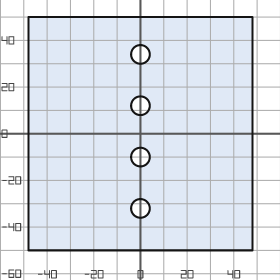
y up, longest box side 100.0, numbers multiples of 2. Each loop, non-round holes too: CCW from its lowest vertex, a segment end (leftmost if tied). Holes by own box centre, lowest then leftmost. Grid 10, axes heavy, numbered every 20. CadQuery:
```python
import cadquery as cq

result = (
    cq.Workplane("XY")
    .moveTo(-48.0, -50.0)
    .lineTo(48.0, -50.0)
    .lineTo(48.0, 50.0)
    .lineTo(-48.0, 50.0)
    .close()
    .moveTo(0.0, -32.0)
    .circle(4.0)
    .moveTo(0.0, -10.0)
    .circle(4.0)
    .moveTo(0.0, 12.0)
    .circle(4.0)
    .moveTo(0.0, 34.0)
    .circle(4.0)
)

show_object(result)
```